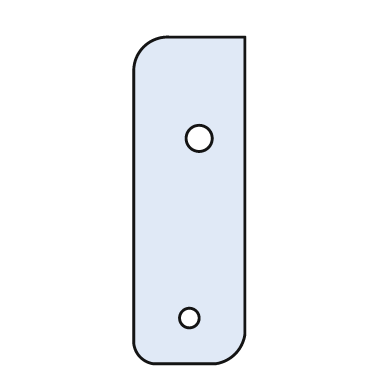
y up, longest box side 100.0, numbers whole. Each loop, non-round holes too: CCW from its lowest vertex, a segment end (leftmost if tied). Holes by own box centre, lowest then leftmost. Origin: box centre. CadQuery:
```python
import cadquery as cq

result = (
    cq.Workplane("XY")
    .moveTo(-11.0, -50.0)
    .lineTo(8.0, -50.0)
    .threePointArc((14.0, -47.0), (17.0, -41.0))
    .lineTo(17.0, 50.0)
    .lineTo(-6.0, 50.0)
    .threePointArc((-14.0, 47.0), (-17.0, 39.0))
    .lineTo(-17.0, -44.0)
    .threePointArc((-15.0, -48.0), (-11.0, -50.0))
    .close()
    .moveTo(0.0, -36.0)
    .circle(3.0)
    .moveTo(3.0, 19.0)
    .circle(4.0)
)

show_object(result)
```